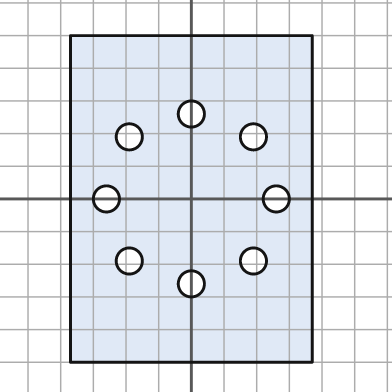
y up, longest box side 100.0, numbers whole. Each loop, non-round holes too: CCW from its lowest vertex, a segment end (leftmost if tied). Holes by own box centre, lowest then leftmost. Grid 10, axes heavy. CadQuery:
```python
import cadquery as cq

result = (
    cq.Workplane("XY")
    .moveTo(-37.0, -50.0)
    .lineTo(37.0, -50.0)
    .lineTo(37.0, 50.0)
    .lineTo(-37.0, 50.0)
    .close()
    .moveTo(0.0, -26.0)
    .circle(4.0)
    .moveTo(-19.0, -19.0)
    .circle(4.0)
    .moveTo(19.0, -19.0)
    .circle(4.0)
    .moveTo(-26.0, 0.0)
    .circle(4.0)
    .moveTo(26.0, 0.0)
    .circle(4.0)
    .moveTo(-19.0, 19.0)
    .circle(4.0)
    .moveTo(19.0, 19.0)
    .circle(4.0)
    .moveTo(0.0, 26.0)
    .circle(4.0)
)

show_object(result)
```